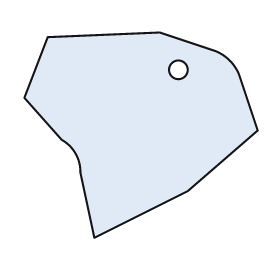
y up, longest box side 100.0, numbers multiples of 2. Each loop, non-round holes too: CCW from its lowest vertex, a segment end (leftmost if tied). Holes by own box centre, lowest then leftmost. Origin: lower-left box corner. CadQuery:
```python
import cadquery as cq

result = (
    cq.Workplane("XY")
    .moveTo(30.0, 0.0)
    .lineTo(70.0, 20.0)
    .lineTo(100.0, 46.0)
    .lineTo(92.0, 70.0)
    .threePointArc((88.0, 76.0), (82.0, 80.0))
    .lineTo(58.0, 88.0)
    .lineTo(10.0, 86.0)
    .lineTo(0.0, 60.0)
    .lineTo(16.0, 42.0)
    .threePointArc((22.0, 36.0), (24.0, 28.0))
    .close()
    .moveTo(66.0, 72.0)
    .circle(4.0)
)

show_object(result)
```